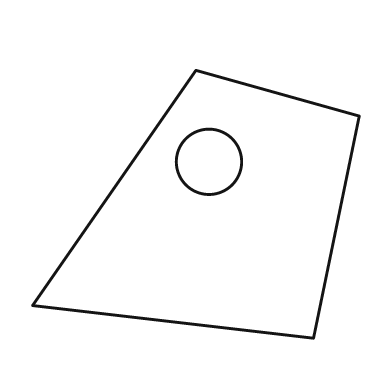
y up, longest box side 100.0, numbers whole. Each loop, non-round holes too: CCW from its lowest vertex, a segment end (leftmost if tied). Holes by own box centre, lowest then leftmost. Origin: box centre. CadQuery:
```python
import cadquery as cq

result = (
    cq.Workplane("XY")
    .moveTo(36.0, -41.0)
    .lineTo(50.0, 27.0)
    .lineTo(0.0, 41.0)
    .lineTo(-50.0, -31.0)
    .close()
    .moveTo(4.0, 13.0)
    .circle(10.0)
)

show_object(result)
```